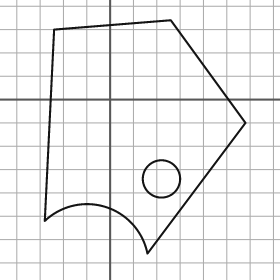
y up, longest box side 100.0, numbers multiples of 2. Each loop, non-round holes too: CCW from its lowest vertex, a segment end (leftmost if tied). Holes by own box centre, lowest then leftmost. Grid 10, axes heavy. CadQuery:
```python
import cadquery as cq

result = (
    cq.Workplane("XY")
    .moveTo(16.0, -66.0)
    .lineTo(58.0, -10.0)
    .lineTo(26.0, 34.0)
    .lineTo(-24.0, 30.0)
    .lineTo(-28.0, -52.0)
    .threePointArc((-2.0, -46.0), (16.0, -66.0))
    .close()
    .moveTo(22.0, -34.0)
    .circle(8.0)
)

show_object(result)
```